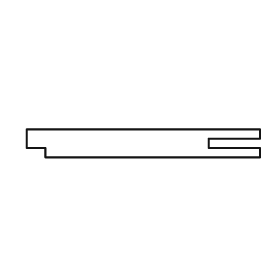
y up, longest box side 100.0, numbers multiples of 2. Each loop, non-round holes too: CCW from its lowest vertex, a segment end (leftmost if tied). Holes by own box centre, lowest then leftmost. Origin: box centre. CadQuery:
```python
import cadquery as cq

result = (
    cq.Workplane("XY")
    .moveTo(-42.0, -6.0)
    .lineTo(50.0, -6.0)
    .lineTo(50.0, -2.0)
    .lineTo(28.0, -2.0)
    .lineTo(28.0, 2.0)
    .lineTo(50.0, 2.0)
    .lineTo(50.0, 6.0)
    .lineTo(-50.0, 6.0)
    .lineTo(-50.0, -2.0)
    .lineTo(-42.0, -2.0)
    .close()
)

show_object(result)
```